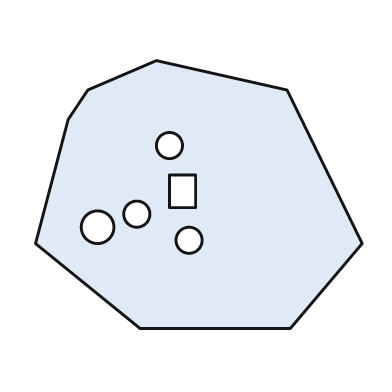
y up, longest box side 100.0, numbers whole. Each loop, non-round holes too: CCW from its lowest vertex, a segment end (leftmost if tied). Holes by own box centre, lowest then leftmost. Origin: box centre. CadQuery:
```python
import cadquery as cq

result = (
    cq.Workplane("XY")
    .moveTo(-18.0, -41.0)
    .lineTo(28.0, -41.0)
    .lineTo(50.0, -15.0)
    .lineTo(27.0, 32.0)
    .lineTo(-13.0, 41.0)
    .lineTo(-34.0, 32.0)
    .lineTo(-40.0, 23.0)
    .lineTo(-50.0, -15.0)
    .close()
    .moveTo(-3.0, -14.0)
    .circle(4.0)
    .moveTo(-31.0, -10.0)
    .circle(5.0)
    .moveTo(-19.0, -6.0)
    .circle(4.0)
    .moveTo(-9.0, -4.0)
    .lineTo(-1.0, -4.0)
    .lineTo(-1.0, 6.0)
    .lineTo(-9.0, 6.0)
    .close()
    .moveTo(-9.0, 15.0)
    .circle(4.0)
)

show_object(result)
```